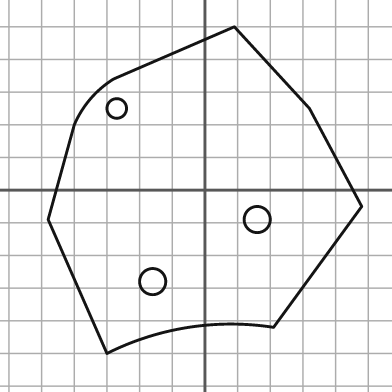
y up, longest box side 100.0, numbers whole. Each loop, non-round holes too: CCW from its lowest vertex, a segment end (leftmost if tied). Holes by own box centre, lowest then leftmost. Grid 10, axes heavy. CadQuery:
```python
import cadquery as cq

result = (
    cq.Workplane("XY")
    .moveTo(-30.0, -50.0)
    .threePointArc((-5.0, -42.0), (21.0, -42.0))
    .lineTo(48.0, -5.0)
    .lineTo(32.0, 25.0)
    .lineTo(9.0, 50.0)
    .lineTo(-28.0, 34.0)
    .threePointArc((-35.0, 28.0), (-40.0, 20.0))
    .lineTo(-48.0, -9.0)
    .close()
    .moveTo(-16.0, -28.0)
    .circle(4.0)
    .moveTo(16.0, -9.0)
    .circle(4.0)
    .moveTo(-27.0, 25.0)
    .circle(3.0)
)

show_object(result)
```